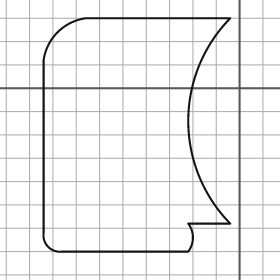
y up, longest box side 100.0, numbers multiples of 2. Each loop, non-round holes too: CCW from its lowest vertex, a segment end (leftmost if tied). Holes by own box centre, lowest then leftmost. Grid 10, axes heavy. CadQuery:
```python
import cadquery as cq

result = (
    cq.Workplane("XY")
    .moveTo(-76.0, -70.0)
    .lineTo(-22.0, -70.0)
    .threePointArc((-20.0, -64.0), (-22.0, -58.0))
    .lineTo(-4.0, -58.0)
    .threePointArc((-22.0, -14.0), (-4.0, 30.0))
    .lineTo(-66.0, 30.0)
    .threePointArc((-78.0, 24.0), (-84.0, 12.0))
    .lineTo(-84.0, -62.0)
    .threePointArc((-82.0, -68.0), (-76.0, -70.0))
    .close()
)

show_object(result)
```